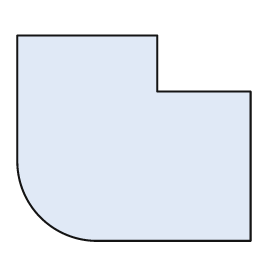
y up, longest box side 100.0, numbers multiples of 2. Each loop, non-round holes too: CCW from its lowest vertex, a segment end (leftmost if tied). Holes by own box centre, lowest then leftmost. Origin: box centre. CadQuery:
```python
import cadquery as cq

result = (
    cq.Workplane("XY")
    .moveTo(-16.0, -44.0)
    .lineTo(50.0, -44.0)
    .lineTo(50.0, 20.0)
    .lineTo(10.0, 20.0)
    .lineTo(10.0, 44.0)
    .lineTo(-50.0, 44.0)
    .lineTo(-50.0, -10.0)
    .threePointArc((-40.0, -34.0), (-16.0, -44.0))
    .close()
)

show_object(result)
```